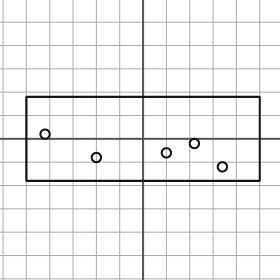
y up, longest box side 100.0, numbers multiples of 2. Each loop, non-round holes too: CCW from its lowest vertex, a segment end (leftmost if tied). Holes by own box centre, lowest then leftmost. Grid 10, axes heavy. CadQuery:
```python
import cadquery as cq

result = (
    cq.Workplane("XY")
    .moveTo(-50.0, -18.0)
    .lineTo(50.0, -18.0)
    .lineTo(50.0, 18.0)
    .lineTo(-50.0, 18.0)
    .close()
    .moveTo(34.0, -12.0)
    .circle(2.0)
    .moveTo(-20.0, -8.0)
    .circle(2.0)
    .moveTo(10.0, -6.0)
    .circle(2.0)
    .moveTo(22.0, -2.0)
    .circle(2.0)
    .moveTo(-42.0, 2.0)
    .circle(2.0)
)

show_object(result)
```